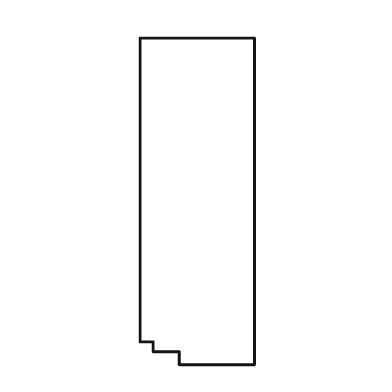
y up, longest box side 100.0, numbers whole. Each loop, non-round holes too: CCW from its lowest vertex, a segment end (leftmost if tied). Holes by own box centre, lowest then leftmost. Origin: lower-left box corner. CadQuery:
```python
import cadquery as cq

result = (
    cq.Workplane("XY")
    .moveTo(12.0, 0.0)
    .lineTo(35.0, 0.0)
    .lineTo(35.0, 100.0)
    .lineTo(0.0, 100.0)
    .lineTo(0.0, 7.0)
    .lineTo(4.0, 7.0)
    .lineTo(4.0, 4.0)
    .lineTo(12.0, 4.0)
    .close()
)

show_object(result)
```